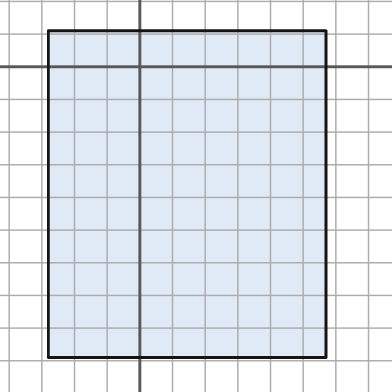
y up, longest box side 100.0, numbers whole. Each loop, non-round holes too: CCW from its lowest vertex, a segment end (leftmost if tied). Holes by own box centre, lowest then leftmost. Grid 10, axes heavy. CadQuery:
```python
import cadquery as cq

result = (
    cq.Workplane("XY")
    .moveTo(-28.0, -89.0)
    .lineTo(57.0, -89.0)
    .lineTo(57.0, 11.0)
    .lineTo(-28.0, 11.0)
    .close()
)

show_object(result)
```